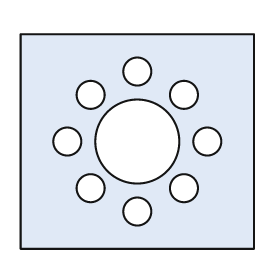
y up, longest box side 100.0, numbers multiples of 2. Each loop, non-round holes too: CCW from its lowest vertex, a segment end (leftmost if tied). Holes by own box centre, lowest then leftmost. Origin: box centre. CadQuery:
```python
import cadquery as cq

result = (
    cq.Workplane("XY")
    .moveTo(-50.0, -46.0)
    .lineTo(50.0, -46.0)
    .lineTo(50.0, 46.0)
    .lineTo(-50.0, 46.0)
    .close()
    .moveTo(0.0, -30.0)
    .circle(6.0)
    .moveTo(-20.0, -20.0)
    .circle(6.0)
    .moveTo(20.0, -20.0)
    .circle(6.0)
    .moveTo(-30.0, 0.0)
    .circle(6.0)
    .moveTo(0.0, 0.0)
    .circle(18.0)
    .moveTo(30.0, 0.0)
    .circle(6.0)
    .moveTo(-20.0, 20.0)
    .circle(6.0)
    .moveTo(20.0, 20.0)
    .circle(6.0)
    .moveTo(0.0, 30.0)
    .circle(6.0)
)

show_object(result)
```